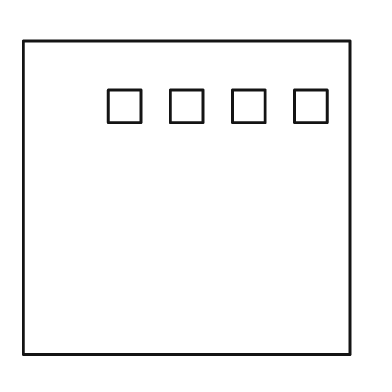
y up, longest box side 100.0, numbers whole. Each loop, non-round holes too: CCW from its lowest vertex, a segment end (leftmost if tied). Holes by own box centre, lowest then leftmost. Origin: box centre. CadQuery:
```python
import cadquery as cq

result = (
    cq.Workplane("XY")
    .moveTo(-50.0, -48.0)
    .lineTo(50.0, -48.0)
    .lineTo(50.0, 48.0)
    .lineTo(-50.0, 48.0)
    .close()
    .moveTo(-24.0, 23.0)
    .lineTo(-14.0, 23.0)
    .lineTo(-14.0, 33.0)
    .lineTo(-24.0, 33.0)
    .close()
    .moveTo(-5.0, 23.0)
    .lineTo(5.0, 23.0)
    .lineTo(5.0, 33.0)
    .lineTo(-5.0, 33.0)
    .close()
    .moveTo(14.0, 23.0)
    .lineTo(24.0, 23.0)
    .lineTo(24.0, 33.0)
    .lineTo(14.0, 33.0)
    .close()
    .moveTo(33.0, 23.0)
    .lineTo(43.0, 23.0)
    .lineTo(43.0, 33.0)
    .lineTo(33.0, 33.0)
    .close()
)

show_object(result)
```